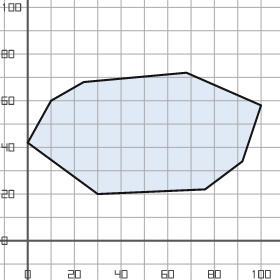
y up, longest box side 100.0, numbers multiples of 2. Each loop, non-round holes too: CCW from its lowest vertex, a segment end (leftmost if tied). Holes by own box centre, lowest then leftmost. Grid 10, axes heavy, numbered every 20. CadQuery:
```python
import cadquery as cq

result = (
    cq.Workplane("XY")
    .moveTo(30.0, 20.0)
    .lineTo(76.0, 22.0)
    .lineTo(92.0, 34.0)
    .lineTo(100.0, 58.0)
    .lineTo(68.0, 72.0)
    .lineTo(24.0, 68.0)
    .lineTo(10.0, 60.0)
    .lineTo(0.0, 42.0)
    .close()
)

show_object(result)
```